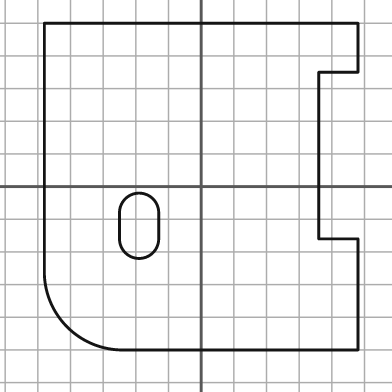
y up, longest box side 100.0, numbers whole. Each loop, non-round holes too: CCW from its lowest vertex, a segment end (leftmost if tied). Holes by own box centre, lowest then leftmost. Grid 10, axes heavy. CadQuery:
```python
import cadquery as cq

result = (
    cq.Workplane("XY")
    .moveTo(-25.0, -50.0)
    .lineTo(48.0, -50.0)
    .lineTo(48.0, -16.0)
    .lineTo(36.0, -16.0)
    .lineTo(36.0, 35.0)
    .lineTo(48.0, 35.0)
    .lineTo(48.0, 50.0)
    .lineTo(-48.0, 50.0)
    .lineTo(-48.0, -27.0)
    .threePointArc((-41.0, -43.0), (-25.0, -50.0))
    .close()
    .moveTo(-25.0, -16.0)
    .threePointArc((-19.0, -22.0), (-13.0, -16.0))
    .lineTo(-13.0, -8.0)
    .threePointArc((-19.0, -2.0), (-25.0, -8.0))
    .close()
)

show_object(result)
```